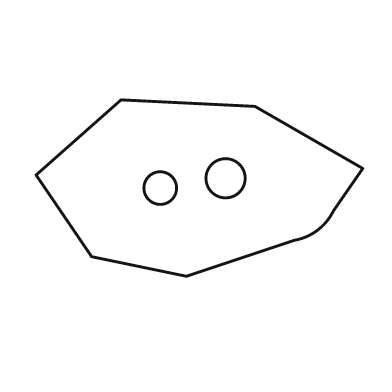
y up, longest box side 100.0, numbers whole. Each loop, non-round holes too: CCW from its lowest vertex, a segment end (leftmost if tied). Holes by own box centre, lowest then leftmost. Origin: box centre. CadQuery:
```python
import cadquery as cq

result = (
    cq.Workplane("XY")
    .moveTo(-4.0, -27.0)
    .lineTo(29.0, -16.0)
    .threePointArc((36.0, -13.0), (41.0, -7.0))
    .lineTo(50.0, 6.0)
    .lineTo(17.0, 25.0)
    .lineTo(-24.0, 27.0)
    .lineTo(-50.0, 4.0)
    .lineTo(-33.0, -21.0)
    .close()
    .moveTo(-12.0, 0.0)
    .circle(5.0)
    .moveTo(8.0, 3.0)
    .circle(6.0)
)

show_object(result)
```